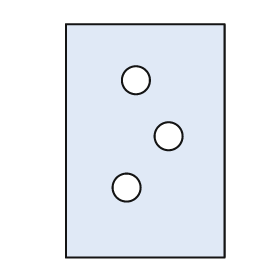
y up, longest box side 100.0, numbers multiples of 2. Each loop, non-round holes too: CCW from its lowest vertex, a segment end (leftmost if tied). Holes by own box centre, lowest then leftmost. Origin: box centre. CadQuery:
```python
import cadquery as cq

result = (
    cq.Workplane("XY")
    .moveTo(-34.0, -50.0)
    .lineTo(34.0, -50.0)
    .lineTo(34.0, 50.0)
    .lineTo(-34.0, 50.0)
    .close()
    .moveTo(-8.0, -20.0)
    .circle(6.0)
    .moveTo(10.0, 2.0)
    .circle(6.0)
    .moveTo(-4.0, 26.0)
    .circle(6.0)
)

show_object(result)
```